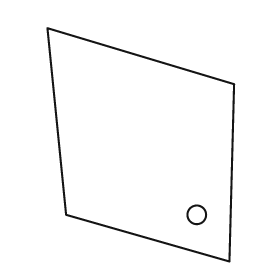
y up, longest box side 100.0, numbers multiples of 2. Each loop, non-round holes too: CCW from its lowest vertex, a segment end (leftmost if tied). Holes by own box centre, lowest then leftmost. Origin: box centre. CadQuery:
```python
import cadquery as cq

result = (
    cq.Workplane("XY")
    .moveTo(38.0, -50.0)
    .lineTo(40.0, 26.0)
    .lineTo(-40.0, 50.0)
    .lineTo(-32.0, -30.0)
    .close()
    .moveTo(24.0, -30.0)
    .circle(4.0)
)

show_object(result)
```